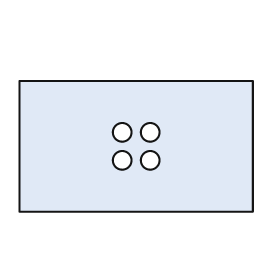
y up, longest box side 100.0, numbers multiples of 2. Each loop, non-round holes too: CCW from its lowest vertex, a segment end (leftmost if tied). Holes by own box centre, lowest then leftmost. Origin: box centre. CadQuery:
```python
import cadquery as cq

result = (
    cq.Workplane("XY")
    .moveTo(-50.0, -28.0)
    .lineTo(50.0, -28.0)
    .lineTo(50.0, 28.0)
    .lineTo(-50.0, 28.0)
    .close()
    .moveTo(-6.0, -6.0)
    .circle(4.0)
    .moveTo(6.0, -6.0)
    .circle(4.0)
    .moveTo(-6.0, 6.0)
    .circle(4.0)
    .moveTo(6.0, 6.0)
    .circle(4.0)
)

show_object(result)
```